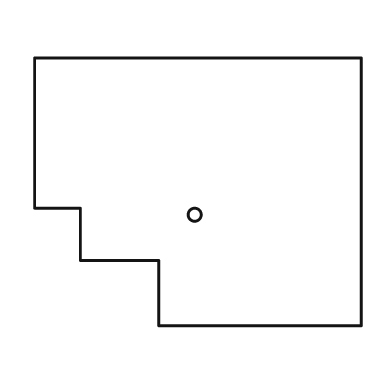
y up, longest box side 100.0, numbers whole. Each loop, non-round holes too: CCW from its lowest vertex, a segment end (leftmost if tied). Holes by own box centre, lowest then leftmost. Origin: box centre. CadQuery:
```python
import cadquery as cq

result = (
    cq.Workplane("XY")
    .moveTo(-12.0, -41.0)
    .lineTo(50.0, -41.0)
    .lineTo(50.0, 41.0)
    .lineTo(-50.0, 41.0)
    .lineTo(-50.0, -5.0)
    .lineTo(-36.0, -5.0)
    .lineTo(-36.0, -21.0)
    .lineTo(-12.0, -21.0)
    .close()
    .moveTo(-1.0, -7.0)
    .circle(2.0)
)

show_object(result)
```